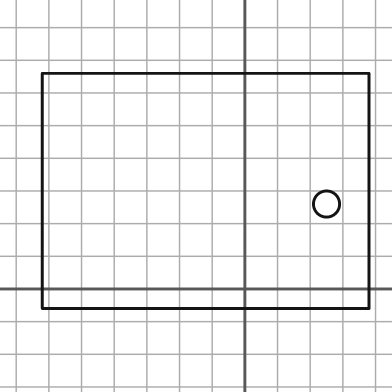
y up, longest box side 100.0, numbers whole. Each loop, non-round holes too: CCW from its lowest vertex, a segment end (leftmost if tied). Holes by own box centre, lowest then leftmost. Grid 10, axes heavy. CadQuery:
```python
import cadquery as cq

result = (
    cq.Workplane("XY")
    .moveTo(-62.0, -6.0)
    .lineTo(38.0, -6.0)
    .lineTo(38.0, 66.0)
    .lineTo(-62.0, 66.0)
    .close()
    .moveTo(25.0, 26.0)
    .circle(4.0)
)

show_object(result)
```